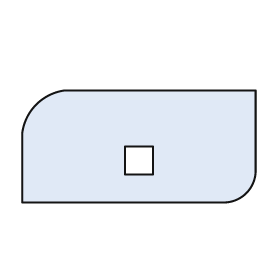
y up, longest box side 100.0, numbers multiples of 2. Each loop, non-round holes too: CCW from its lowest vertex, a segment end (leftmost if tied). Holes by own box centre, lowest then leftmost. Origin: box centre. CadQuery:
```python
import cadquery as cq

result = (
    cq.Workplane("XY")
    .moveTo(-50.0, -24.0)
    .lineTo(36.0, -24.0)
    .threePointArc((46.0, -20.0), (50.0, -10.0))
    .lineTo(50.0, 24.0)
    .lineTo(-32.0, 24.0)
    .threePointArc((-44.0, 18.0), (-50.0, 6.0))
    .close()
    .moveTo(-6.0, -12.0)
    .lineTo(6.0, -12.0)
    .lineTo(6.0, 0.0)
    .lineTo(-6.0, 0.0)
    .close()
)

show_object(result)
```